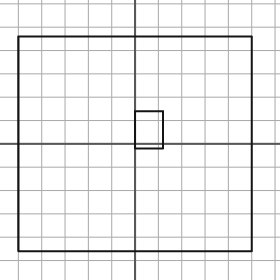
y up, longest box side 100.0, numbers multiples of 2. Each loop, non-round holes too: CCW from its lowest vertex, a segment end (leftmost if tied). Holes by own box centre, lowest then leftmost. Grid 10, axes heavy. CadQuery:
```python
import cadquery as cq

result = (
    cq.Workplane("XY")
    .moveTo(-50.0, -46.0)
    .lineTo(50.0, -46.0)
    .lineTo(50.0, 46.0)
    .lineTo(-50.0, 46.0)
    .close()
    .moveTo(0.0, -2.0)
    .lineTo(12.0, -2.0)
    .lineTo(12.0, 14.0)
    .lineTo(0.0, 14.0)
    .close()
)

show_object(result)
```